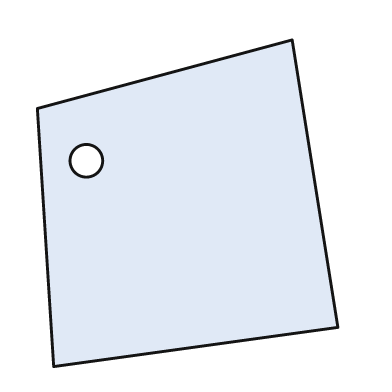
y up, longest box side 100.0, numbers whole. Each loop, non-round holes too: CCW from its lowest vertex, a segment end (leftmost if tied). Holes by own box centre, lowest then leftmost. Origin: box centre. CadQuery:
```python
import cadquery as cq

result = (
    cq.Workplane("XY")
    .moveTo(-41.0, -50.0)
    .lineTo(46.0, -38.0)
    .lineTo(32.0, 50.0)
    .lineTo(-46.0, 29.0)
    .close()
    .moveTo(-31.0, 13.0)
    .circle(5.0)
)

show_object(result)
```